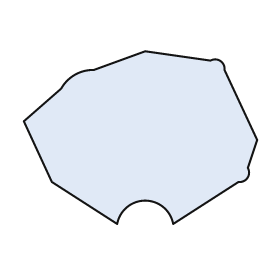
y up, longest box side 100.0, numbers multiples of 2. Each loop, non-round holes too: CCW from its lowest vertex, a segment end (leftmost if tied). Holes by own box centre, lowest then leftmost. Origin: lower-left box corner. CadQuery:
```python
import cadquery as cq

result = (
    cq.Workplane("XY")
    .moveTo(40.0, 0.0)
    .threePointArc((52.0, 10.0), (64.0, 0.0))
    .lineTo(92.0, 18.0)
    .threePointArc((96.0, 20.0), (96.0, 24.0))
    .lineTo(100.0, 36.0)
    .lineTo(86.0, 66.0)
    .threePointArc((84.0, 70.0), (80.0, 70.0))
    .lineTo(52.0, 74.0)
    .lineTo(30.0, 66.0)
    .threePointArc((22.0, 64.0), (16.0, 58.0))
    .lineTo(0.0, 44.0)
    .lineTo(12.0, 18.0)
    .close()
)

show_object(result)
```